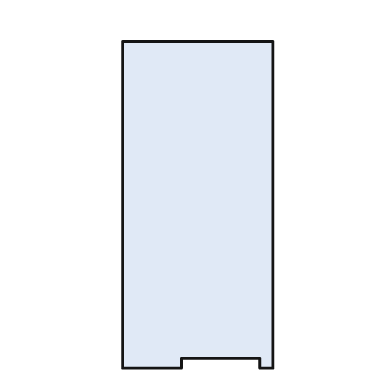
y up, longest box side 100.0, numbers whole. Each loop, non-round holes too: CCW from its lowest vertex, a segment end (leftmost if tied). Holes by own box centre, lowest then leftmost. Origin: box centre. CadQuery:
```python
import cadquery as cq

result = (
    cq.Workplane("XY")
    .moveTo(-23.0, -50.0)
    .lineTo(-5.0, -50.0)
    .lineTo(-5.0, -47.0)
    .lineTo(19.0, -47.0)
    .lineTo(19.0, -50.0)
    .lineTo(23.0, -50.0)
    .lineTo(23.0, 50.0)
    .lineTo(-23.0, 50.0)
    .close()
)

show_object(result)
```